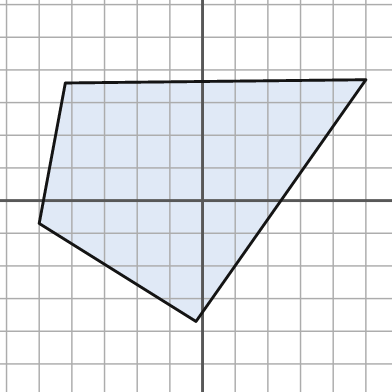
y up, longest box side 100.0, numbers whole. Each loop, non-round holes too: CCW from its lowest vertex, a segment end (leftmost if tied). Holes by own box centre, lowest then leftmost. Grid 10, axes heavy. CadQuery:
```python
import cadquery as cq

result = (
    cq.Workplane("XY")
    .moveTo(-2.0, -37.0)
    .lineTo(50.0, 37.0)
    .lineTo(-42.0, 36.0)
    .lineTo(-50.0, -7.0)
    .close()
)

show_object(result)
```